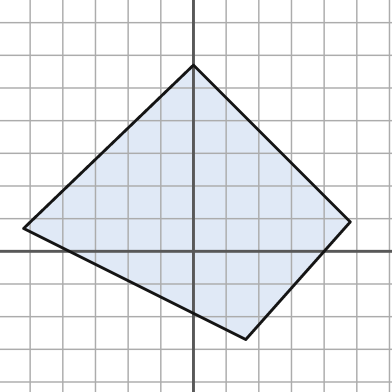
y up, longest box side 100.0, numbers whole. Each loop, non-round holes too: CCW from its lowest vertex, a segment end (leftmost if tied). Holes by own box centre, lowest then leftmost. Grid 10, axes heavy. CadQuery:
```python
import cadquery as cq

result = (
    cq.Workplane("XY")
    .moveTo(16.0, -27.0)
    .lineTo(48.0, 9.0)
    .lineTo(0.0, 57.0)
    .lineTo(-52.0, 7.0)
    .close()
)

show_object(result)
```